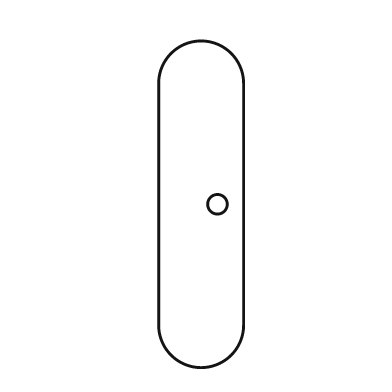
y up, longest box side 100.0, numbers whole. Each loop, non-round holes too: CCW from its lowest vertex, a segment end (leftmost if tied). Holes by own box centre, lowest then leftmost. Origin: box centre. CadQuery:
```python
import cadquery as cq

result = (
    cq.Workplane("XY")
    .moveTo(-13.0, -37.0)
    .threePointArc((0.0, -50.0), (13.0, -37.0))
    .lineTo(13.0, 37.0)
    .threePointArc((0.0, 50.0), (-13.0, 37.0))
    .close()
    .moveTo(5.0, 0.0)
    .circle(3.0)
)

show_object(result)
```